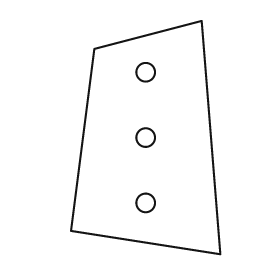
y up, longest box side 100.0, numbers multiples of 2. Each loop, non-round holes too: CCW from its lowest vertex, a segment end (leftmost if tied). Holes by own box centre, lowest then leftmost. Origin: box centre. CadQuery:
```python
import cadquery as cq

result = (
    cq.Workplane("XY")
    .moveTo(32.0, -50.0)
    .lineTo(24.0, 50.0)
    .lineTo(-22.0, 38.0)
    .lineTo(-32.0, -40.0)
    .close()
    .moveTo(0.0, -28.0)
    .circle(4.0)
    .moveTo(0.0, 0.0)
    .circle(4.0)
    .moveTo(0.0, 28.0)
    .circle(4.0)
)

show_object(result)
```